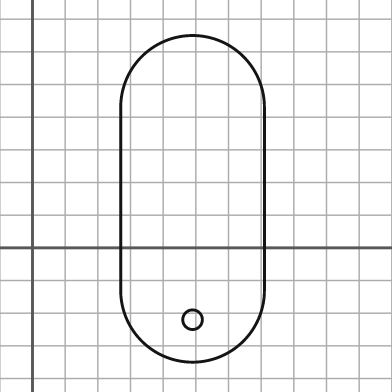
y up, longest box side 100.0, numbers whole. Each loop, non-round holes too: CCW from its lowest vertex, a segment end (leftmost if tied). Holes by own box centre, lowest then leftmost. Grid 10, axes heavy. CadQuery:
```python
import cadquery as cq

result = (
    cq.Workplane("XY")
    .moveTo(27.0, -13.0)
    .threePointArc((49.0, -35.0), (71.0, -13.0))
    .lineTo(71.0, 43.0)
    .threePointArc((49.0, 65.0), (27.0, 43.0))
    .close()
    .moveTo(49.0, -22.0)
    .circle(3.0)
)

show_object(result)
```